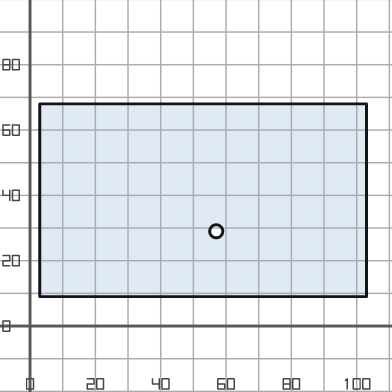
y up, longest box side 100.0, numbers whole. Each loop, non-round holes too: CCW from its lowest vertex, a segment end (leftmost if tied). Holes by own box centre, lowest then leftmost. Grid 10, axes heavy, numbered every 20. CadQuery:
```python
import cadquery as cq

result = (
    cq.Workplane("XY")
    .moveTo(3.0, 9.0)
    .lineTo(103.0, 9.0)
    .lineTo(103.0, 68.0)
    .lineTo(3.0, 68.0)
    .close()
    .moveTo(57.0, 29.0)
    .circle(2.0)
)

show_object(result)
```